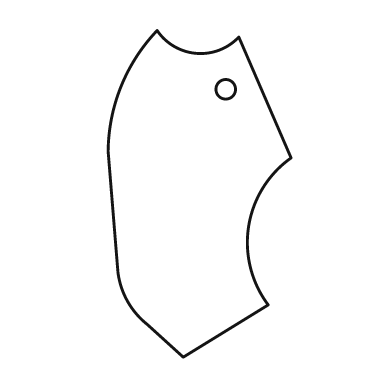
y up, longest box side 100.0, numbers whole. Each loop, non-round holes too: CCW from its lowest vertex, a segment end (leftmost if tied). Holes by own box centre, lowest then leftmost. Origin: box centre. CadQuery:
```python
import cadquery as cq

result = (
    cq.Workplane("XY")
    .moveTo(-5.0, -50.0)
    .lineTo(21.0, -34.0)
    .threePointArc((15.0, -10.0), (28.0, 11.0))
    .lineTo(12.0, 48.0)
    .threePointArc((-1.0, 43.0), (-13.0, 50.0))
    .threePointArc((-24.0, 33.0), (-28.0, 13.0))
    .lineTo(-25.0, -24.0)
    .threePointArc((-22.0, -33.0), (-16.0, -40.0))
    .close()
    .moveTo(8.0, 32.0)
    .circle(3.0)
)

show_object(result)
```